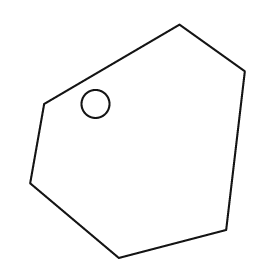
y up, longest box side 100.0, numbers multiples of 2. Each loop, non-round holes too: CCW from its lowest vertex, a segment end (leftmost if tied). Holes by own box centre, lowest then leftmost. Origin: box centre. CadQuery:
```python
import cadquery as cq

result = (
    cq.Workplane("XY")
    .moveTo(-8.0, -50.0)
    .lineTo(38.0, -38.0)
    .lineTo(46.0, 30.0)
    .lineTo(18.0, 50.0)
    .lineTo(-40.0, 16.0)
    .lineTo(-46.0, -18.0)
    .close()
    .moveTo(-18.0, 16.0)
    .circle(6.0)
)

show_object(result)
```